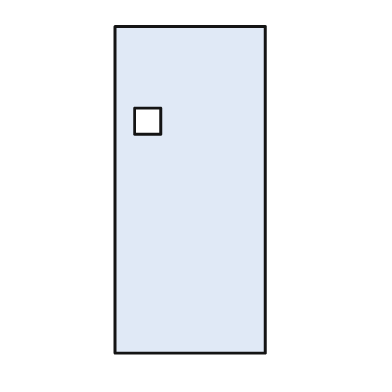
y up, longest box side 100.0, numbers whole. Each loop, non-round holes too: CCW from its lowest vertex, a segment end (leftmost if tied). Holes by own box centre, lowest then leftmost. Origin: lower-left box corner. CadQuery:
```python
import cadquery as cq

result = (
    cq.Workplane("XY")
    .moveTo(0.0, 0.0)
    .lineTo(46.0, 0.0)
    .lineTo(46.0, 100.0)
    .lineTo(0.0, 100.0)
    .close()
    .moveTo(6.0, 67.0)
    .lineTo(14.0, 67.0)
    .lineTo(14.0, 75.0)
    .lineTo(6.0, 75.0)
    .close()
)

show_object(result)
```